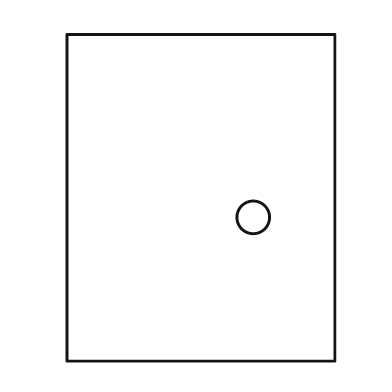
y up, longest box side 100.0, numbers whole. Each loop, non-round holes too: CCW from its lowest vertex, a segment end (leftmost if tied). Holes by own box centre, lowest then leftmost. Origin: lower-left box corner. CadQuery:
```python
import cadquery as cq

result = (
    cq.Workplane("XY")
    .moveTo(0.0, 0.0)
    .lineTo(82.0, 0.0)
    .lineTo(82.0, 100.0)
    .lineTo(0.0, 100.0)
    .close()
    .moveTo(57.0, 44.0)
    .circle(5.0)
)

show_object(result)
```